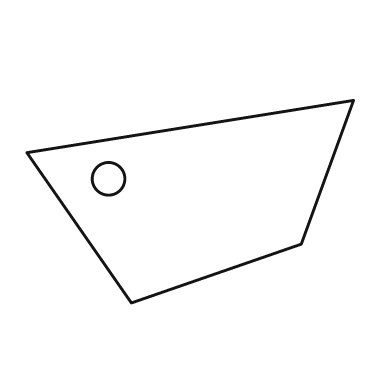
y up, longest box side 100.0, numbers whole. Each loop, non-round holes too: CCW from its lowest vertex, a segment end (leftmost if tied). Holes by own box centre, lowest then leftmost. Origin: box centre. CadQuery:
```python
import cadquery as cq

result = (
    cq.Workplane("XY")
    .moveTo(-18.0, -31.0)
    .lineTo(34.0, -13.0)
    .lineTo(50.0, 31.0)
    .lineTo(-50.0, 15.0)
    .close()
    .moveTo(-25.0, 7.0)
    .circle(5.0)
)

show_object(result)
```